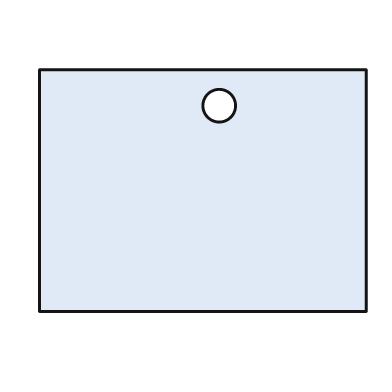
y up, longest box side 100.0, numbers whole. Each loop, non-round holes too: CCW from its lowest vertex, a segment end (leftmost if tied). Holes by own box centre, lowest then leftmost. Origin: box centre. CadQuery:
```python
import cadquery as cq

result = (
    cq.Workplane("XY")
    .moveTo(-50.0, -37.0)
    .lineTo(50.0, -37.0)
    .lineTo(50.0, 37.0)
    .lineTo(-50.0, 37.0)
    .close()
    .moveTo(5.0, 26.0)
    .circle(5.0)
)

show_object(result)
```